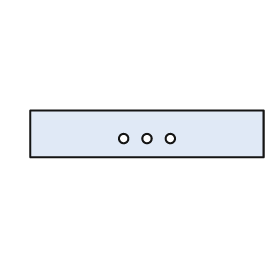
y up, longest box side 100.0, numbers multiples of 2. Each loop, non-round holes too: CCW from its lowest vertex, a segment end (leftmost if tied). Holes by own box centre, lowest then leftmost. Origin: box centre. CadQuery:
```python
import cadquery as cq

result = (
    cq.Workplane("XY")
    .moveTo(-50.0, -10.0)
    .lineTo(50.0, -10.0)
    .lineTo(50.0, 10.0)
    .lineTo(-50.0, 10.0)
    .close()
    .moveTo(-10.0, -2.0)
    .circle(2.0)
    .moveTo(0.0, -2.0)
    .circle(2.0)
    .moveTo(10.0, -2.0)
    .circle(2.0)
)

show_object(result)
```